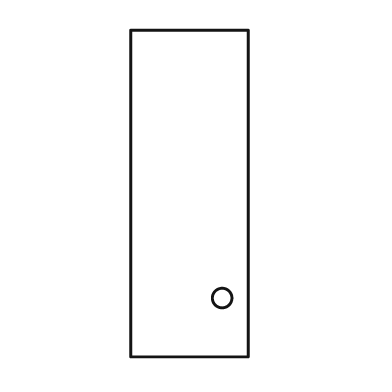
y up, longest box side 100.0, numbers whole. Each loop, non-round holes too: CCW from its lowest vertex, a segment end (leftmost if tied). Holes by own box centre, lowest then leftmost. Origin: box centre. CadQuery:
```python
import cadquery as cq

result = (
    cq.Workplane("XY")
    .moveTo(-18.0, -50.0)
    .lineTo(18.0, -50.0)
    .lineTo(18.0, 50.0)
    .lineTo(-18.0, 50.0)
    .close()
    .moveTo(10.0, -32.0)
    .circle(3.0)
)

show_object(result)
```